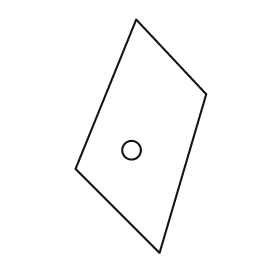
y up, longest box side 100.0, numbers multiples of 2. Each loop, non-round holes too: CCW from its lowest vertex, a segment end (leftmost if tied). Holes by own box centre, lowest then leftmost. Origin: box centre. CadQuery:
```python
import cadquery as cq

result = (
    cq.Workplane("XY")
    .moveTo(8.0, -50.0)
    .lineTo(28.0, 18.0)
    .lineTo(-2.0, 50.0)
    .lineTo(-28.0, -14.0)
    .close()
    .moveTo(-4.0, -6.0)
    .circle(4.0)
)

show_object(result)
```